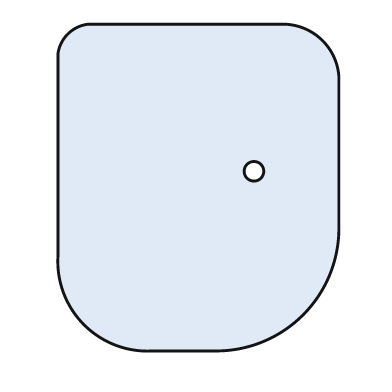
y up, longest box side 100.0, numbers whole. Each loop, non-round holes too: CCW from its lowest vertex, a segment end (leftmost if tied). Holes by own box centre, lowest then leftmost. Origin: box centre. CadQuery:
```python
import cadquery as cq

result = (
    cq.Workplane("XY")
    .moveTo(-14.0, -50.0)
    .lineTo(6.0, -50.0)
    .threePointArc((32.0, -39.0), (43.0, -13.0))
    .lineTo(43.0, 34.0)
    .threePointArc((38.0, 45.0), (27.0, 50.0))
    .lineTo(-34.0, 50.0)
    .threePointArc((-40.0, 47.0), (-43.0, 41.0))
    .lineTo(-43.0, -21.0)
    .threePointArc((-35.0, -42.0), (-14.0, -50.0))
    .close()
    .moveTo(17.0, 5.0)
    .circle(3.0)
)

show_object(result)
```